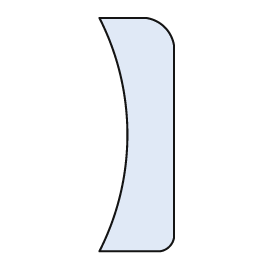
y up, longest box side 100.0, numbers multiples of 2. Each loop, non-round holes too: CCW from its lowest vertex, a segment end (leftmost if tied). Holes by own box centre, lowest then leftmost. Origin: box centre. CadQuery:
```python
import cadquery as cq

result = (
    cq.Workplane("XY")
    .moveTo(-16.0, -50.0)
    .lineTo(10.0, -50.0)
    .threePointArc((14.0, -48.0), (16.0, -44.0))
    .lineTo(16.0, 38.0)
    .threePointArc((12.0, 46.0), (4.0, 50.0))
    .lineTo(-16.0, 50.0)
    .threePointArc((-4.0, 0.0), (-16.0, -50.0))
    .close()
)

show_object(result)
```